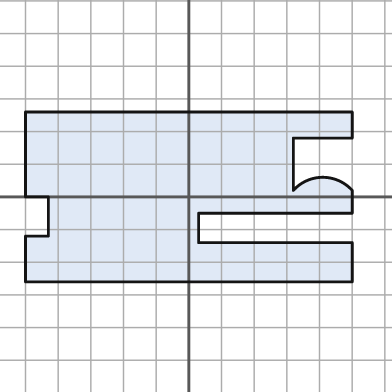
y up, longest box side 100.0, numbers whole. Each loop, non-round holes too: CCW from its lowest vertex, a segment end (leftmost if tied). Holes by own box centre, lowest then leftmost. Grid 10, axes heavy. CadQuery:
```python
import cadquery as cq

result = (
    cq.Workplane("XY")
    .moveTo(-50.0, -26.0)
    .lineTo(50.0, -26.0)
    .lineTo(50.0, -14.0)
    .lineTo(3.0, -14.0)
    .lineTo(3.0, -5.0)
    .lineTo(50.0, -5.0)
    .lineTo(50.0, 2.0)
    .threePointArc((41.0, 6.0), (32.0, 2.0))
    .lineTo(32.0, 18.0)
    .lineTo(50.0, 18.0)
    .lineTo(50.0, 26.0)
    .lineTo(-50.0, 26.0)
    .lineTo(-50.0, 0.0)
    .lineTo(-43.0, 0.0)
    .lineTo(-43.0, -12.0)
    .lineTo(-50.0, -12.0)
    .close()
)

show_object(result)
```